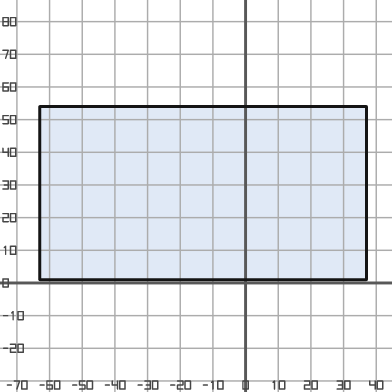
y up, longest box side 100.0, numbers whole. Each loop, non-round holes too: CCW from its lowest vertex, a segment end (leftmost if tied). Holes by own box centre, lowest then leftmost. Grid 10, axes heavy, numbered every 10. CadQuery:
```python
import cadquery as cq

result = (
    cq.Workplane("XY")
    .moveTo(-63.0, 1.0)
    .lineTo(37.0, 1.0)
    .lineTo(37.0, 54.0)
    .lineTo(-63.0, 54.0)
    .close()
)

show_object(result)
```